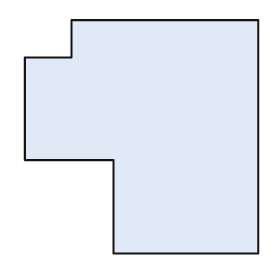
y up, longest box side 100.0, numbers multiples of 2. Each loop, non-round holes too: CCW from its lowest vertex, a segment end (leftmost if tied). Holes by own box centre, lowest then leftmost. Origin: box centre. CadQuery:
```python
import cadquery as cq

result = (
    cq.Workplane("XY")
    .moveTo(-12.0, -50.0)
    .lineTo(50.0, -50.0)
    .lineTo(50.0, 50.0)
    .lineTo(-30.0, 50.0)
    .lineTo(-30.0, 34.0)
    .lineTo(-50.0, 34.0)
    .lineTo(-50.0, -10.0)
    .lineTo(-12.0, -10.0)
    .close()
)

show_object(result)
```